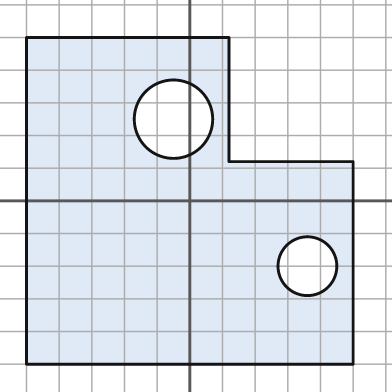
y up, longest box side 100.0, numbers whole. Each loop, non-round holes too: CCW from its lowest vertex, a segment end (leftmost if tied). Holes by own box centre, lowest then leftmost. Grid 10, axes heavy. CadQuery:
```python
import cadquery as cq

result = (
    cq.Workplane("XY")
    .moveTo(-50.0, -50.0)
    .lineTo(50.0, -50.0)
    .lineTo(50.0, 12.0)
    .lineTo(12.0, 12.0)
    .lineTo(12.0, 50.0)
    .lineTo(-50.0, 50.0)
    .close()
    .moveTo(36.0, -20.0)
    .circle(9.0)
    .moveTo(-5.0, 25.0)
    .circle(12.0)
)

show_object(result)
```